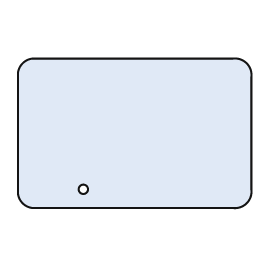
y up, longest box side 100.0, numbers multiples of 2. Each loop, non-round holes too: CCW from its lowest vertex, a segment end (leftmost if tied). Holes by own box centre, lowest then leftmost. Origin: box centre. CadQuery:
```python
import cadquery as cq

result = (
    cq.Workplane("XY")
    .moveTo(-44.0, -32.0)
    .lineTo(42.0, -32.0)
    .threePointArc((48.0, -30.0), (50.0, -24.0))
    .lineTo(50.0, 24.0)
    .threePointArc((48.0, 30.0), (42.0, 32.0))
    .lineTo(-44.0, 32.0)
    .threePointArc((-48.0, 30.0), (-50.0, 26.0))
    .lineTo(-50.0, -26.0)
    .threePointArc((-48.0, -30.0), (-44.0, -32.0))
    .close()
    .moveTo(-22.0, -24.0)
    .circle(2.0)
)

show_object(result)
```